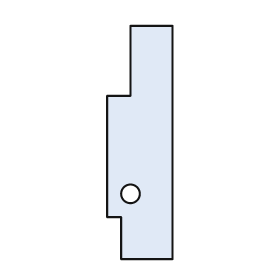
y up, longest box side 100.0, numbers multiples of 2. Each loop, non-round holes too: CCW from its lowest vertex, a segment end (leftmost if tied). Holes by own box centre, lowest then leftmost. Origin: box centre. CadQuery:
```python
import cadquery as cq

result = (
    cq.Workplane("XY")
    .moveTo(-8.0, -50.0)
    .lineTo(14.0, -50.0)
    .lineTo(14.0, 50.0)
    .lineTo(-4.0, 50.0)
    .lineTo(-4.0, 20.0)
    .lineTo(-14.0, 20.0)
    .lineTo(-14.0, -32.0)
    .lineTo(-8.0, -32.0)
    .close()
    .moveTo(-4.0, -22.0)
    .circle(4.0)
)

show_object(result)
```